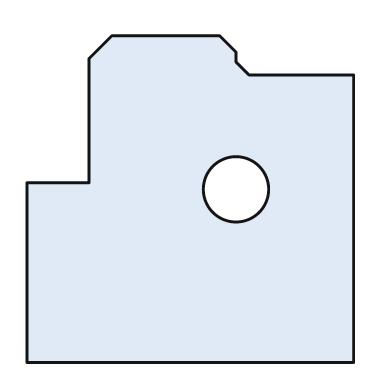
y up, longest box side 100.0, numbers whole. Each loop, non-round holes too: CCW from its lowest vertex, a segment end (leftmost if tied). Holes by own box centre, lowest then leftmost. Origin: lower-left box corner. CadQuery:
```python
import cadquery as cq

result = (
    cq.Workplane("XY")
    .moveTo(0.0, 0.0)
    .lineTo(100.0, 0.0)
    .lineTo(100.0, 88.0)
    .lineTo(68.0, 88.0)
    .lineTo(64.0, 92.0)
    .lineTo(64.0, 95.0)
    .lineTo(59.0, 100.0)
    .lineTo(26.0, 100.0)
    .lineTo(19.0, 93.0)
    .lineTo(19.0, 55.0)
    .lineTo(0.0, 55.0)
    .close()
    .moveTo(64.0, 53.0)
    .circle(10.0)
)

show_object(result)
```